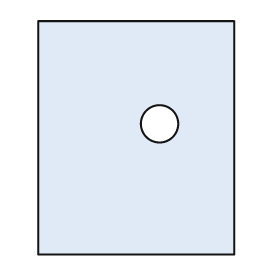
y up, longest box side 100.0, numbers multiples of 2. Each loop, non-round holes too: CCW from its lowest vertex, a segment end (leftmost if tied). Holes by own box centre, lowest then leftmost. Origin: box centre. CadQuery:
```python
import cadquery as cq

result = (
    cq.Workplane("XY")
    .moveTo(-42.0, -50.0)
    .lineTo(42.0, -50.0)
    .lineTo(42.0, 50.0)
    .lineTo(-42.0, 50.0)
    .close()
    .moveTo(10.0, 6.0)
    .circle(8.0)
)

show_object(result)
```